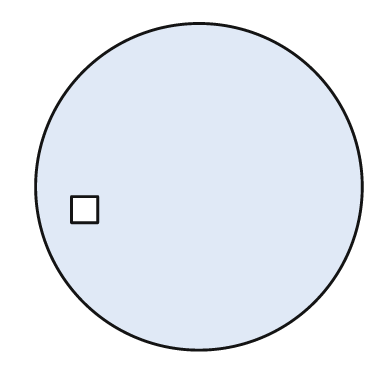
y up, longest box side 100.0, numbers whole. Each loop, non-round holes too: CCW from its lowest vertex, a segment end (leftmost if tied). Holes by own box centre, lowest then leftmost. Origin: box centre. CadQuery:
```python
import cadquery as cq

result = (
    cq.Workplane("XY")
    .moveTo(0.0, 0.0)
    .circle(50.0)
    .moveTo(-39.0, -11.0)
    .lineTo(-31.0, -11.0)
    .lineTo(-31.0, -3.0)
    .lineTo(-39.0, -3.0)
    .close()
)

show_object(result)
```